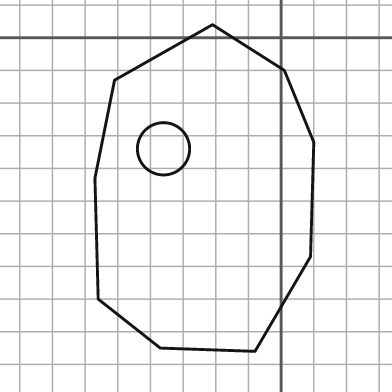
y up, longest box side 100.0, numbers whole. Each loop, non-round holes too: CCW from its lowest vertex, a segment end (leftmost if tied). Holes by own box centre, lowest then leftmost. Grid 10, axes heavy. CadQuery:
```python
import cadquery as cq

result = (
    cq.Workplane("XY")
    .moveTo(-8.0, -96.0)
    .lineTo(9.0, -67.0)
    .lineTo(10.0, -32.0)
    .lineTo(1.0, -10.0)
    .lineTo(-21.0, 4.0)
    .lineTo(-51.0, -13.0)
    .lineTo(-57.0, -43.0)
    .lineTo(-56.0, -80.0)
    .lineTo(-37.0, -95.0)
    .close()
    .moveTo(-36.0, -34.0)
    .circle(8.0)
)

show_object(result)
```